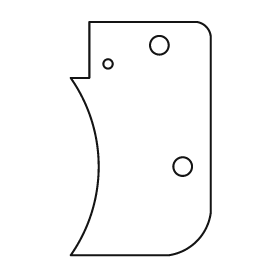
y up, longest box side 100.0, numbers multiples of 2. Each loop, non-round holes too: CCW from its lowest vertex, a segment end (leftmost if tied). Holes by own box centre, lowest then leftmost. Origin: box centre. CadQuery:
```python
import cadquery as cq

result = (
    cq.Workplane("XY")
    .moveTo(-30.0, -50.0)
    .lineTo(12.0, -50.0)
    .threePointArc((24.0, -44.0), (30.0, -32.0))
    .lineTo(30.0, 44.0)
    .threePointArc((28.0, 48.0), (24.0, 50.0))
    .lineTo(-22.0, 50.0)
    .lineTo(-22.0, 26.0)
    .lineTo(-30.0, 26.0)
    .threePointArc((-18.0, -12.0), (-30.0, -50.0))
    .close()
    .moveTo(18.0, -12.0)
    .circle(4.0)
    .moveTo(-14.0, 32.0)
    .circle(2.0)
    .moveTo(8.0, 40.0)
    .circle(4.0)
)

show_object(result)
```